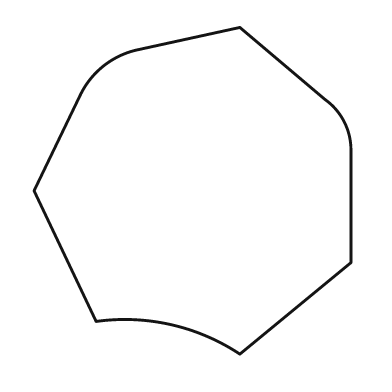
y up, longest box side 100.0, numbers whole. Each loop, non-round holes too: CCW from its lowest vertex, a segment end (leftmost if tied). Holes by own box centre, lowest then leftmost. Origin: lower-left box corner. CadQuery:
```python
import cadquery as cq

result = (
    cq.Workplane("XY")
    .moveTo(63.0, 0.0)
    .lineTo(97.0, 28.0)
    .lineTo(97.0, 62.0)
    .threePointArc((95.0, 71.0), (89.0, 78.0))
    .lineTo(63.0, 100.0)
    .lineTo(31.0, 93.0)
    .threePointArc((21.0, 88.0), (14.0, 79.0))
    .lineTo(0.0, 50.0)
    .lineTo(19.0, 10.0)
    .threePointArc((42.0, 9.0), (63.0, 0.0))
    .close()
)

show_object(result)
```